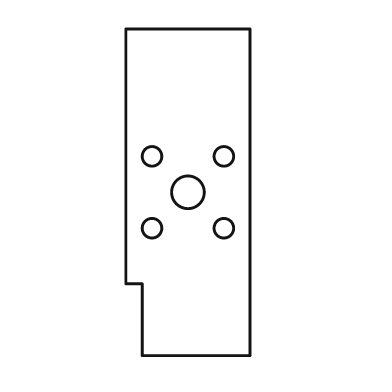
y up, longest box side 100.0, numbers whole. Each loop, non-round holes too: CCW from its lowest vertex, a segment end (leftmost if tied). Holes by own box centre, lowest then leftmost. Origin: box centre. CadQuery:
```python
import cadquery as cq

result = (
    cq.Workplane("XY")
    .moveTo(-14.0, -50.0)
    .lineTo(19.0, -50.0)
    .lineTo(19.0, 50.0)
    .lineTo(-19.0, 50.0)
    .lineTo(-19.0, -28.0)
    .lineTo(-14.0, -28.0)
    .close()
    .moveTo(-11.0, -11.0)
    .circle(3.0)
    .moveTo(11.0, -11.0)
    .circle(3.0)
    .moveTo(0.0, 0.0)
    .circle(5.0)
    .moveTo(-11.0, 11.0)
    .circle(3.0)
    .moveTo(11.0, 11.0)
    .circle(3.0)
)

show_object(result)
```